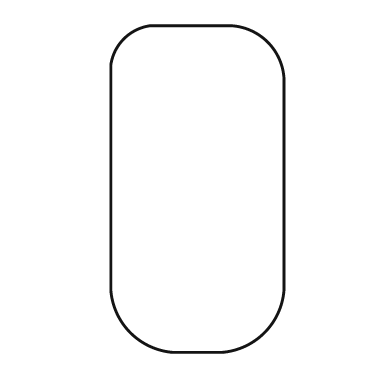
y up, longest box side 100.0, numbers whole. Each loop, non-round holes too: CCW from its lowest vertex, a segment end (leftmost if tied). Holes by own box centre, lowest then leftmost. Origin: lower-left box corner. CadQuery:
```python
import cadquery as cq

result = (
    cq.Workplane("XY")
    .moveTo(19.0, 0.0)
    .lineTo(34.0, 0.0)
    .threePointArc((47.0, 6.0), (53.0, 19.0))
    .lineTo(53.0, 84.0)
    .threePointArc((48.0, 95.0), (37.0, 100.0))
    .lineTo(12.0, 100.0)
    .threePointArc((4.0, 96.0), (0.0, 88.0))
    .lineTo(0.0, 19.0)
    .threePointArc((6.0, 6.0), (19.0, 0.0))
    .close()
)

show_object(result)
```